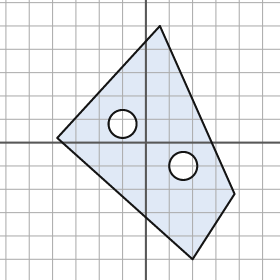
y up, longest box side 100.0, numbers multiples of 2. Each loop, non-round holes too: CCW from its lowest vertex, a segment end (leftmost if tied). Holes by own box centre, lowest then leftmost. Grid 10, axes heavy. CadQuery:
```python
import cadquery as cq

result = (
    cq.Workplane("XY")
    .moveTo(20.0, -50.0)
    .lineTo(38.0, -22.0)
    .lineTo(6.0, 50.0)
    .lineTo(-38.0, 2.0)
    .close()
    .moveTo(16.0, -10.0)
    .circle(6.0)
    .moveTo(-10.0, 8.0)
    .circle(6.0)
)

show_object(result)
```